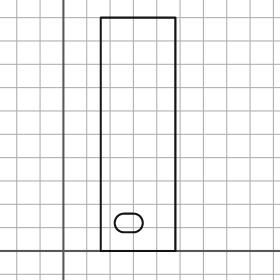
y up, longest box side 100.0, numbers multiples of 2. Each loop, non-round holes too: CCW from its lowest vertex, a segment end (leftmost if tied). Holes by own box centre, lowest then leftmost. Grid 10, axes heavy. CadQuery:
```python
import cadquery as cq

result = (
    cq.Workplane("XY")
    .moveTo(16.0, 0.0)
    .lineTo(48.0, 0.0)
    .lineTo(48.0, 100.0)
    .lineTo(16.0, 100.0)
    .close()
    .moveTo(26.0, 8.0)
    .lineTo(30.0, 8.0)
    .threePointArc((34.0, 12.0), (30.0, 16.0))
    .lineTo(26.0, 16.0)
    .threePointArc((22.0, 12.0), (26.0, 8.0))
    .close()
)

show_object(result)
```